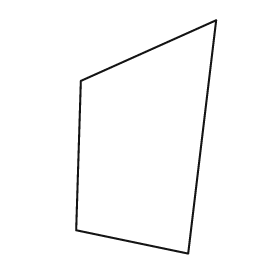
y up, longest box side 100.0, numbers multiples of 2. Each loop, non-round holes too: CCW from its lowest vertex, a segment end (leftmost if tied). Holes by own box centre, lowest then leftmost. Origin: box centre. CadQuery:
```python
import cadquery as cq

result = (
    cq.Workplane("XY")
    .moveTo(18.0, -50.0)
    .lineTo(30.0, 50.0)
    .lineTo(-28.0, 24.0)
    .lineTo(-30.0, -40.0)
    .close()
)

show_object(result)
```